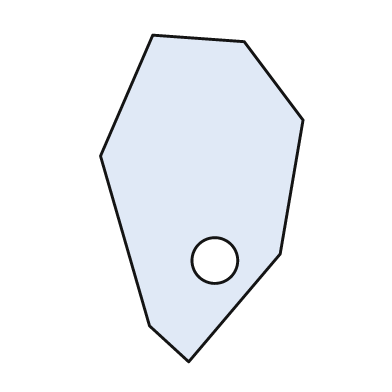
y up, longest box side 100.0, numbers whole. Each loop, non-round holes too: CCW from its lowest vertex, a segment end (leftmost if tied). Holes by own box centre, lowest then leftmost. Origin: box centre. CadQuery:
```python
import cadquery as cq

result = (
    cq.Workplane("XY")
    .moveTo(-4.0, -50.0)
    .lineTo(24.0, -17.0)
    .lineTo(31.0, 24.0)
    .lineTo(13.0, 48.0)
    .lineTo(-15.0, 50.0)
    .lineTo(-31.0, 13.0)
    .lineTo(-16.0, -39.0)
    .close()
    .moveTo(4.0, -19.0)
    .circle(7.0)
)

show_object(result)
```